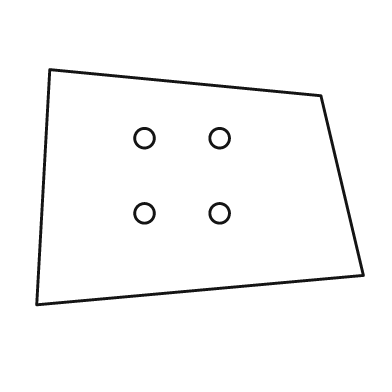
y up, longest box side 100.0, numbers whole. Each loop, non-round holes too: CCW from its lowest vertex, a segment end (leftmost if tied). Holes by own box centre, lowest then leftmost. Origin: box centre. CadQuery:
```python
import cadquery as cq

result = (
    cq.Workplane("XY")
    .moveTo(-50.0, -36.0)
    .lineTo(50.0, -27.0)
    .lineTo(37.0, 28.0)
    .lineTo(-46.0, 36.0)
    .close()
    .moveTo(-17.0, -8.0)
    .circle(3.0)
    .moveTo(6.0, -8.0)
    .circle(3.0)
    .moveTo(-17.0, 15.0)
    .circle(3.0)
    .moveTo(6.0, 15.0)
    .circle(3.0)
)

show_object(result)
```